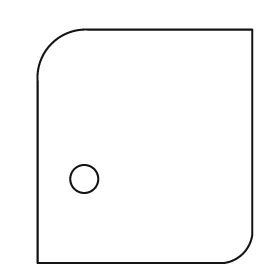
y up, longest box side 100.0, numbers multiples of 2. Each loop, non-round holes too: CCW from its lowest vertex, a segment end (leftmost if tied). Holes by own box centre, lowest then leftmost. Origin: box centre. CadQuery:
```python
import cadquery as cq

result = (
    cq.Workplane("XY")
    .moveTo(-46.0, -50.0)
    .lineTo(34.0, -50.0)
    .threePointArc((42.0, -46.0), (46.0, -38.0))
    .lineTo(46.0, 50.0)
    .lineTo(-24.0, 50.0)
    .threePointArc((-40.0, 44.0), (-46.0, 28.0))
    .close()
    .moveTo(-26.0, -14.0)
    .circle(6.0)
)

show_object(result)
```